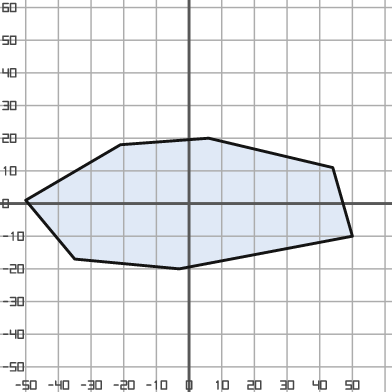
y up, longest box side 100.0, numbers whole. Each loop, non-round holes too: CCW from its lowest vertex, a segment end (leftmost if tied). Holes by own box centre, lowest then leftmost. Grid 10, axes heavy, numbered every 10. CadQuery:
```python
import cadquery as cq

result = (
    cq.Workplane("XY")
    .moveTo(-3.0, -20.0)
    .lineTo(50.0, -10.0)
    .lineTo(44.0, 11.0)
    .lineTo(6.0, 20.0)
    .lineTo(-21.0, 18.0)
    .lineTo(-50.0, 1.0)
    .lineTo(-35.0, -17.0)
    .close()
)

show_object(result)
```